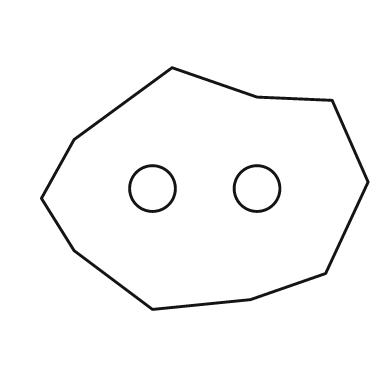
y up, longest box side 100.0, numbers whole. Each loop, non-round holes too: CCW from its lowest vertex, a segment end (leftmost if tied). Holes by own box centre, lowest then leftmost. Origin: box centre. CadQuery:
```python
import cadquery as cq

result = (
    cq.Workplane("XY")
    .moveTo(-16.0, -37.0)
    .lineTo(14.0, -34.0)
    .lineTo(37.0, -26.0)
    .lineTo(50.0, 2.0)
    .lineTo(39.0, 27.0)
    .lineTo(16.0, 28.0)
    .lineTo(-10.0, 37.0)
    .lineTo(-40.0, 15.0)
    .lineTo(-50.0, -3.0)
    .lineTo(-40.0, -19.0)
    .close()
    .moveTo(-16.0, 0.0)
    .circle(7.0)
    .moveTo(16.0, 0.0)
    .circle(7.0)
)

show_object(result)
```